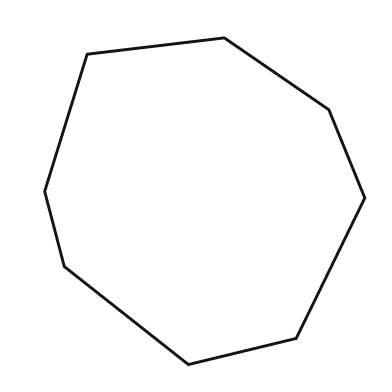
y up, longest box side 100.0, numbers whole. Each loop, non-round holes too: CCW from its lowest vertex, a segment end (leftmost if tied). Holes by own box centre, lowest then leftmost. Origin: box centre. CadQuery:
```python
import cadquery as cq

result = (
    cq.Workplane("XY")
    .moveTo(-5.0, -50.0)
    .lineTo(28.0, -42.0)
    .lineTo(49.0, 1.0)
    .lineTo(38.0, 28.0)
    .lineTo(6.0, 50.0)
    .lineTo(-36.0, 45.0)
    .lineTo(-49.0, 3.0)
    .lineTo(-43.0, -20.0)
    .close()
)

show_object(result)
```